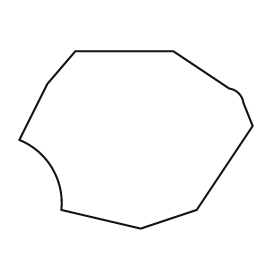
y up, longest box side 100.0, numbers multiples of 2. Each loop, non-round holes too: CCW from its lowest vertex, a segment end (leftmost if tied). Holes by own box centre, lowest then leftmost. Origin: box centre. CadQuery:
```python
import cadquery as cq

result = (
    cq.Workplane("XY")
    .moveTo(2.0, -38.0)
    .lineTo(26.0, -30.0)
    .lineTo(50.0, 6.0)
    .lineTo(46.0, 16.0)
    .threePointArc((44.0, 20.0), (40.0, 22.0))
    .lineTo(16.0, 38.0)
    .lineTo(-26.0, 38.0)
    .lineTo(-38.0, 24.0)
    .lineTo(-50.0, 0.0)
    .threePointArc((-36.0, -12.0), (-32.0, -30.0))
    .close()
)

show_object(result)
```